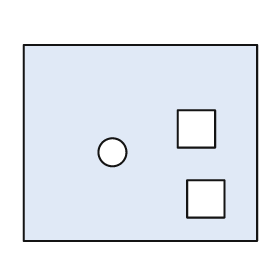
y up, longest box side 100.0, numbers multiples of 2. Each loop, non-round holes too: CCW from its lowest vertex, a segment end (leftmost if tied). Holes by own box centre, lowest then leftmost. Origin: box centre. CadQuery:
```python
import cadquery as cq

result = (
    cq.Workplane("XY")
    .moveTo(-50.0, -42.0)
    .lineTo(50.0, -42.0)
    .lineTo(50.0, 42.0)
    .lineTo(-50.0, 42.0)
    .close()
    .moveTo(20.0, -32.0)
    .lineTo(36.0, -32.0)
    .lineTo(36.0, -16.0)
    .lineTo(20.0, -16.0)
    .close()
    .moveTo(-12.0, -4.0)
    .circle(6.0)
    .moveTo(16.0, -2.0)
    .lineTo(32.0, -2.0)
    .lineTo(32.0, 14.0)
    .lineTo(16.0, 14.0)
    .close()
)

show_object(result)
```